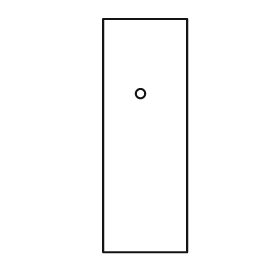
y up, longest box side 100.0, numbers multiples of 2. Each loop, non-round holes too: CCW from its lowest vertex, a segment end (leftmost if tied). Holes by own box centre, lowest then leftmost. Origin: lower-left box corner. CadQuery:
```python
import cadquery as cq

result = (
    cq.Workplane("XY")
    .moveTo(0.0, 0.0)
    .lineTo(36.0, 0.0)
    .lineTo(36.0, 100.0)
    .lineTo(0.0, 100.0)
    .close()
    .moveTo(16.0, 68.0)
    .circle(2.0)
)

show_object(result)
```